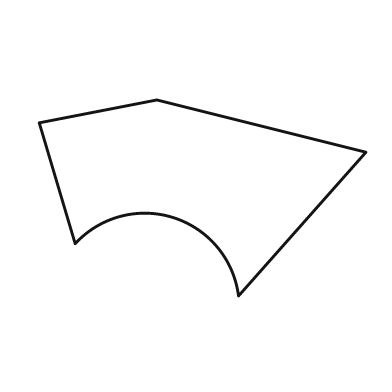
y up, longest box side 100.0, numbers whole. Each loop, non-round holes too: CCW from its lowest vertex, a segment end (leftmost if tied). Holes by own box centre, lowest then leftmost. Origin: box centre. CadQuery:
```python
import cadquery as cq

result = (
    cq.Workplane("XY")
    .moveTo(11.0, -30.0)
    .lineTo(50.0, 14.0)
    .lineTo(-14.0, 30.0)
    .lineTo(-50.0, 23.0)
    .lineTo(-39.0, -14.0)
    .threePointArc((-9.0, -6.0), (11.0, -30.0))
    .close()
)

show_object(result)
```